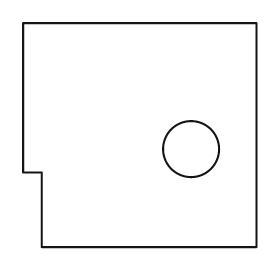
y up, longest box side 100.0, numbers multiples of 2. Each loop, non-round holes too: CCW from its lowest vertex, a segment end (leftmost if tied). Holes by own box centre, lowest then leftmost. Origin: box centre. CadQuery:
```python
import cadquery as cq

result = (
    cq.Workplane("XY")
    .moveTo(-42.0, -48.0)
    .lineTo(50.0, -48.0)
    .lineTo(50.0, 48.0)
    .lineTo(-50.0, 48.0)
    .lineTo(-50.0, -16.0)
    .lineTo(-42.0, -16.0)
    .close()
    .moveTo(22.0, -6.0)
    .circle(12.0)
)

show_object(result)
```